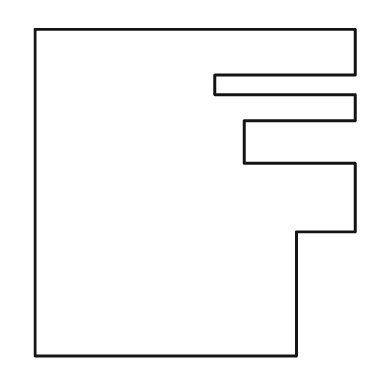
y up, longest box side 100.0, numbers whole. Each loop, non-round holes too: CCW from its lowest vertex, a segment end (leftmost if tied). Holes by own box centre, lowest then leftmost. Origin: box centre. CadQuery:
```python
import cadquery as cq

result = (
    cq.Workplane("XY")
    .moveTo(-49.0, -50.0)
    .lineTo(31.0, -50.0)
    .lineTo(31.0, -12.0)
    .lineTo(49.0, -12.0)
    .lineTo(49.0, 9.0)
    .lineTo(15.0, 9.0)
    .lineTo(15.0, 22.0)
    .lineTo(49.0, 22.0)
    .lineTo(49.0, 30.0)
    .lineTo(6.0, 30.0)
    .lineTo(6.0, 36.0)
    .lineTo(49.0, 36.0)
    .lineTo(49.0, 50.0)
    .lineTo(-49.0, 50.0)
    .close()
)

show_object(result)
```